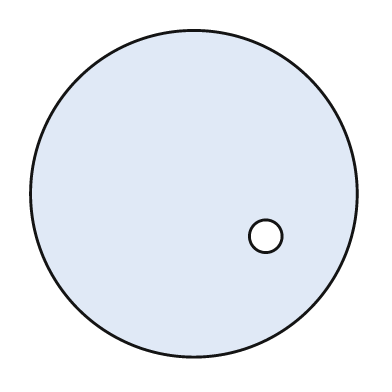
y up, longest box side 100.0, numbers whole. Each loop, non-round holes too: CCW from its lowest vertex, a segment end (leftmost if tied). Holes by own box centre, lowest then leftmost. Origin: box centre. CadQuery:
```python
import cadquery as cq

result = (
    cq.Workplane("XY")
    .moveTo(0.0, 0.0)
    .circle(50.0)
    .moveTo(22.0, -13.0)
    .circle(5.0)
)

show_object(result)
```